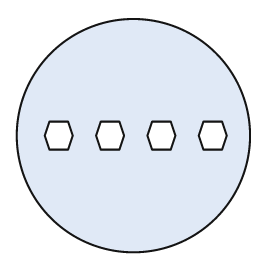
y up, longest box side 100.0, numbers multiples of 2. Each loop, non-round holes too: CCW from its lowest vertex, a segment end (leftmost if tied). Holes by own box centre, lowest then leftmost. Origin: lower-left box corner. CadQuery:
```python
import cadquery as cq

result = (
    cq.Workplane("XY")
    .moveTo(50.0, 50.0)
    .circle(50.0)
    .moveTo(14.0, 44.0)
    .lineTo(22.0, 44.0)
    .lineTo(24.0, 50.0)
    .lineTo(22.0, 56.0)
    .lineTo(14.0, 56.0)
    .lineTo(12.0, 50.0)
    .close()
    .moveTo(36.0, 44.0)
    .lineTo(44.0, 44.0)
    .lineTo(46.0, 50.0)
    .lineTo(44.0, 56.0)
    .lineTo(36.0, 56.0)
    .lineTo(34.0, 50.0)
    .close()
    .moveTo(58.0, 44.0)
    .lineTo(66.0, 44.0)
    .lineTo(68.0, 50.0)
    .lineTo(66.0, 56.0)
    .lineTo(58.0, 56.0)
    .lineTo(56.0, 50.0)
    .close()
    .moveTo(80.0, 44.0)
    .lineTo(88.0, 44.0)
    .lineTo(90.0, 50.0)
    .lineTo(88.0, 56.0)
    .lineTo(80.0, 56.0)
    .lineTo(78.0, 50.0)
    .close()
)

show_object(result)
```